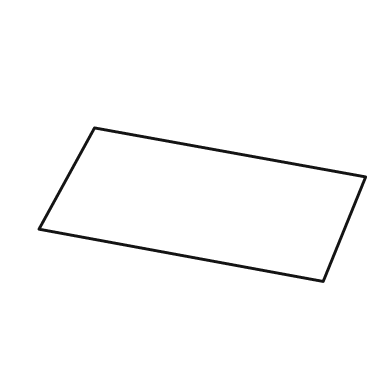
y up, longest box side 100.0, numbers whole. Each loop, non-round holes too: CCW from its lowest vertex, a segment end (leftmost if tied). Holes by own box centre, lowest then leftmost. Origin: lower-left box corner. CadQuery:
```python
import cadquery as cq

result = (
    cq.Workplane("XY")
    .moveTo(87.0, 0.0)
    .lineTo(100.0, 32.0)
    .lineTo(17.0, 47.0)
    .lineTo(0.0, 16.0)
    .close()
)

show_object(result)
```